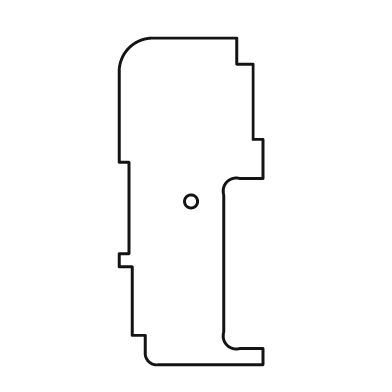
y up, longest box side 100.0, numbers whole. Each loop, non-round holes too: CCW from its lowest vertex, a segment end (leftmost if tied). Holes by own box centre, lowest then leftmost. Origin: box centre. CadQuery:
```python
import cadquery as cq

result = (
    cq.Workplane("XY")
    .moveTo(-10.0, -50.0)
    .lineTo(22.0, -50.0)
    .lineTo(22.0, -45.0)
    .lineTo(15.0, -45.0)
    .threePointArc((11.0, -44.0), (10.0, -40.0))
    .lineTo(10.0, 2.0)
    .threePointArc((11.0, 6.0), (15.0, 7.0))
    .lineTo(22.0, 7.0)
    .lineTo(22.0, 19.0)
    .lineTo(19.0, 19.0)
    .lineTo(19.0, 42.0)
    .lineTo(14.0, 42.0)
    .lineTo(14.0, 50.0)
    .lineTo(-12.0, 50.0)
    .threePointArc((-19.0, 47.0), (-22.0, 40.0))
    .lineTo(-22.0, 12.0)
    .lineTo(-19.0, 12.0)
    .lineTo(-19.0, -16.0)
    .lineTo(-22.0, -16.0)
    .lineTo(-22.0, -20.0)
    .lineTo(-18.0, -20.0)
    .lineTo(-18.0, -41.0)
    .lineTo(-14.0, -41.0)
    .lineTo(-14.0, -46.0)
    .threePointArc((-13.0, -49.0), (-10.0, -50.0))
    .close()
    .moveTo(0.0, 0.0)
    .circle(2.0)
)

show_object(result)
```